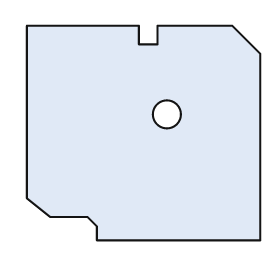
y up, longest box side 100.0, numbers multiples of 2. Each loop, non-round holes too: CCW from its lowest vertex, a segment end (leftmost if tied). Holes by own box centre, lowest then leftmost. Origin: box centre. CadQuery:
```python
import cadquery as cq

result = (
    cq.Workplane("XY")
    .moveTo(-20.0, -46.0)
    .lineTo(50.0, -46.0)
    .lineTo(50.0, 34.0)
    .lineTo(38.0, 46.0)
    .lineTo(6.0, 46.0)
    .lineTo(6.0, 38.0)
    .lineTo(-2.0, 38.0)
    .lineTo(-2.0, 46.0)
    .lineTo(-50.0, 46.0)
    .lineTo(-50.0, -28.0)
    .lineTo(-40.0, -36.0)
    .lineTo(-24.0, -36.0)
    .lineTo(-20.0, -40.0)
    .close()
    .moveTo(10.0, 8.0)
    .circle(6.0)
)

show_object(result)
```